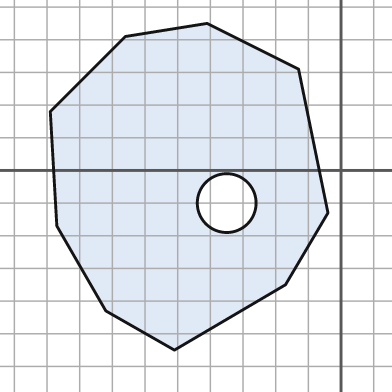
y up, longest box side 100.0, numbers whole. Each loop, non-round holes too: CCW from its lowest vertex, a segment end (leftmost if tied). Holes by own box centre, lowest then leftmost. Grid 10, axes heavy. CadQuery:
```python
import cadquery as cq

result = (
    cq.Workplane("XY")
    .moveTo(-51.0, -55.0)
    .lineTo(-17.0, -35.0)
    .lineTo(-4.0, -13.0)
    .lineTo(-13.0, 31.0)
    .lineTo(-41.0, 45.0)
    .lineTo(-66.0, 41.0)
    .lineTo(-89.0, 18.0)
    .lineTo(-87.0, -17.0)
    .lineTo(-72.0, -43.0)
    .close()
    .moveTo(-35.0, -10.0)
    .circle(9.0)
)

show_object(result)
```